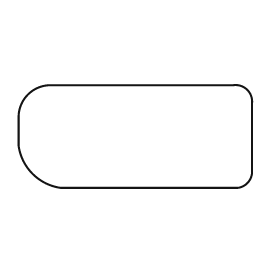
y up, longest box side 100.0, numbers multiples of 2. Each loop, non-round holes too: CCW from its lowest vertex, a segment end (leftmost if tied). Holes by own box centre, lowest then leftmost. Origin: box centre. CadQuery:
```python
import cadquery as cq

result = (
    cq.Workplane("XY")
    .moveTo(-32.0, -22.0)
    .lineTo(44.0, -22.0)
    .threePointArc((48.0, -20.0), (50.0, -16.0))
    .lineTo(50.0, 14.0)
    .threePointArc((48.0, 20.0), (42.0, 22.0))
    .lineTo(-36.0, 22.0)
    .threePointArc((-46.0, 18.0), (-50.0, 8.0))
    .lineTo(-50.0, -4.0)
    .threePointArc((-44.0, -16.0), (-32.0, -22.0))
    .close()
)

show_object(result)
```